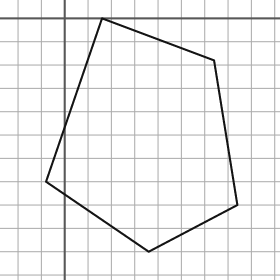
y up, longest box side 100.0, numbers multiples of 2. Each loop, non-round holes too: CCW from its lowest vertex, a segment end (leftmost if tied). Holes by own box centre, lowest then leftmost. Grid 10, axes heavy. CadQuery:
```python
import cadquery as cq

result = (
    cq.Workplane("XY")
    .moveTo(36.0, -100.0)
    .lineTo(74.0, -80.0)
    .lineTo(64.0, -18.0)
    .lineTo(16.0, 0.0)
    .lineTo(-8.0, -70.0)
    .close()
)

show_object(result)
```